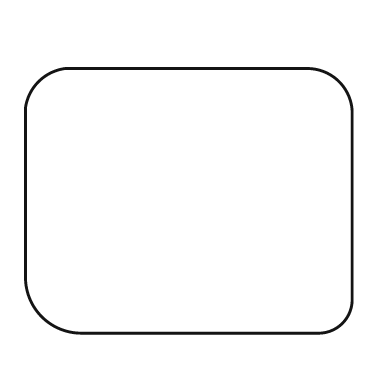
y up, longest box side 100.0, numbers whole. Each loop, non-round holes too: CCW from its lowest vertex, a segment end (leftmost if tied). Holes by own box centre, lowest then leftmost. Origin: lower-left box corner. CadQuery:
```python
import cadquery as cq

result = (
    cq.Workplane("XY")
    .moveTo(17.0, 0.0)
    .lineTo(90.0, 0.0)
    .threePointArc((97.0, 3.0), (100.0, 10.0))
    .lineTo(100.0, 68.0)
    .threePointArc((96.0, 77.0), (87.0, 81.0))
    .lineTo(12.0, 81.0)
    .threePointArc((4.0, 77.0), (0.0, 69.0))
    .lineTo(0.0, 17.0)
    .threePointArc((5.0, 5.0), (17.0, 0.0))
    .close()
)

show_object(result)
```